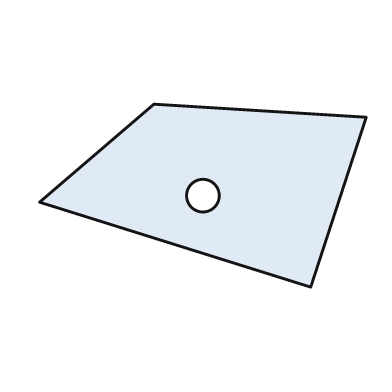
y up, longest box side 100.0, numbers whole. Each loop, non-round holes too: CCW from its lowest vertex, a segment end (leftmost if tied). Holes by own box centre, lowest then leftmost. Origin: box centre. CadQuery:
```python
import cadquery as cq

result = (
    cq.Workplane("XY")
    .moveTo(33.0, -28.0)
    .lineTo(50.0, 24.0)
    .lineTo(-15.0, 28.0)
    .lineTo(-50.0, -2.0)
    .close()
    .moveTo(0.0, 0.0)
    .circle(5.0)
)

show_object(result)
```